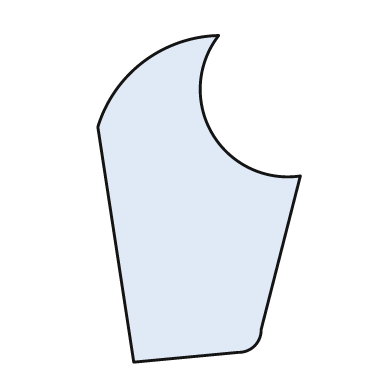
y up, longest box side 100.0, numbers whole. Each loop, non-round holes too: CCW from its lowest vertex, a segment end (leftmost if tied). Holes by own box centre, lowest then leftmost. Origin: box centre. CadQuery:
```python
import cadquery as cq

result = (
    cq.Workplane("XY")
    .moveTo(-20.0, -50.0)
    .lineTo(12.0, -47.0)
    .threePointArc((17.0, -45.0), (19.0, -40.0))
    .lineTo(31.0, 7.0)
    .threePointArc((4.0, 20.0), (6.0, 50.0))
    .threePointArc((-17.0, 42.0), (-31.0, 22.0))
    .close()
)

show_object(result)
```